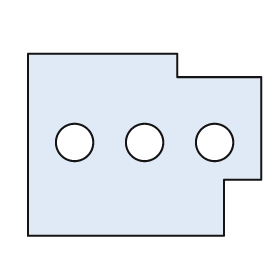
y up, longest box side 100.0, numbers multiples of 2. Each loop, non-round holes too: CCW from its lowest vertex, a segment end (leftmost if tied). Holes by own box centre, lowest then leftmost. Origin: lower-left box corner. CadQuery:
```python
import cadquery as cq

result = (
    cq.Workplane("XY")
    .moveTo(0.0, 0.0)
    .lineTo(84.0, 0.0)
    .lineTo(84.0, 24.0)
    .lineTo(100.0, 24.0)
    .lineTo(100.0, 68.0)
    .lineTo(64.0, 68.0)
    .lineTo(64.0, 78.0)
    .lineTo(0.0, 78.0)
    .close()
    .moveTo(20.0, 40.0)
    .circle(8.0)
    .moveTo(50.0, 40.0)
    .circle(8.0)
    .moveTo(80.0, 40.0)
    .circle(8.0)
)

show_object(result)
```